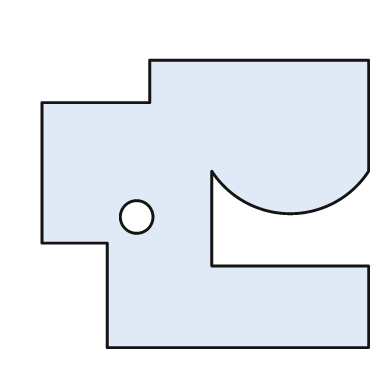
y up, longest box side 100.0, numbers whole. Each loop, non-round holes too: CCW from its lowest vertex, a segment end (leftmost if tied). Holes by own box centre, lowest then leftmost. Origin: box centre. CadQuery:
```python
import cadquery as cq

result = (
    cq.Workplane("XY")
    .moveTo(-30.0, -44.0)
    .lineTo(50.0, -44.0)
    .lineTo(50.0, -19.0)
    .lineTo(2.0, -19.0)
    .lineTo(2.0, 10.0)
    .threePointArc((26.0, -3.0), (50.0, 10.0))
    .lineTo(50.0, 44.0)
    .lineTo(-17.0, 44.0)
    .lineTo(-17.0, 31.0)
    .lineTo(-50.0, 31.0)
    .lineTo(-50.0, -12.0)
    .lineTo(-30.0, -12.0)
    .close()
    .moveTo(-21.0, -4.0)
    .circle(5.0)
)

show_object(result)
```